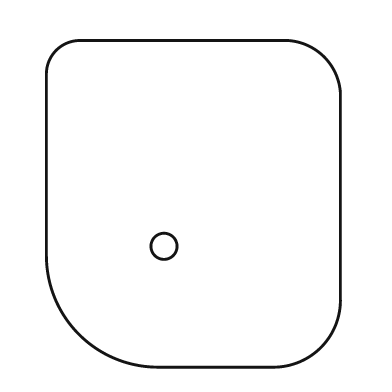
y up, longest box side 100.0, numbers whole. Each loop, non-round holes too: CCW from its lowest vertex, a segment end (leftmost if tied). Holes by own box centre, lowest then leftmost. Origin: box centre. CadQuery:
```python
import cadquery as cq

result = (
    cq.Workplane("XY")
    .moveTo(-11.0, -50.0)
    .lineTo(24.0, -50.0)
    .threePointArc((39.0, -44.0), (45.0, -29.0))
    .lineTo(45.0, 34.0)
    .threePointArc((40.0, 45.0), (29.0, 50.0))
    .lineTo(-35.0, 50.0)
    .threePointArc((-42.0, 47.0), (-45.0, 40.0))
    .lineTo(-45.0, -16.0)
    .threePointArc((-35.0, -40.0), (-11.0, -50.0))
    .close()
    .moveTo(-9.0, -13.0)
    .circle(4.0)
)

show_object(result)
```